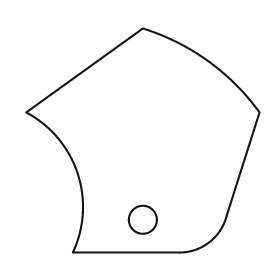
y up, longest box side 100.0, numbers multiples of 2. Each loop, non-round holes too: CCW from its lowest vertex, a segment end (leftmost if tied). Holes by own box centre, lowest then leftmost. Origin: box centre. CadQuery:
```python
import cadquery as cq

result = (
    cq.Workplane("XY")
    .moveTo(-30.0, -48.0)
    .lineTo(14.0, -48.0)
    .threePointArc((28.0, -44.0), (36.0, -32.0))
    .lineTo(50.0, 12.0)
    .threePointArc((28.0, 34.0), (0.0, 48.0))
    .lineTo(-50.0, 12.0)
    .threePointArc((-28.0, -14.0), (-30.0, -48.0))
    .close()
    .moveTo(0.0, -34.0)
    .circle(6.0)
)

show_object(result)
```